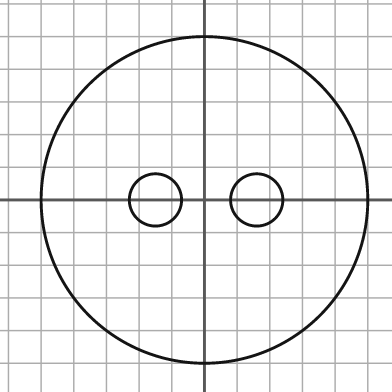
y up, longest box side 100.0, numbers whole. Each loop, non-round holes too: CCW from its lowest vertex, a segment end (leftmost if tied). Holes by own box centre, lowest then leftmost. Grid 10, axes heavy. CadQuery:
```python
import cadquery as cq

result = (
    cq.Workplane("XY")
    .moveTo(0.0, 0.0)
    .circle(50.0)
    .moveTo(-15.0, 0.0)
    .circle(8.0)
    .moveTo(16.0, 0.0)
    .circle(8.0)
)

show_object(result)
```